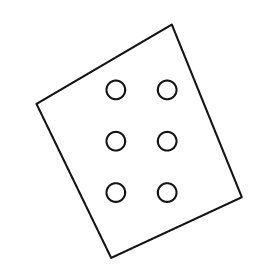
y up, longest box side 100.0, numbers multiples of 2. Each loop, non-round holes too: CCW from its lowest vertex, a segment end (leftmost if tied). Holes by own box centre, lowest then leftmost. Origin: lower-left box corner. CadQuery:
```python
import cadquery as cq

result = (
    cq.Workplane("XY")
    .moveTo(32.0, 0.0)
    .lineTo(88.0, 26.0)
    .lineTo(58.0, 100.0)
    .lineTo(0.0, 66.0)
    .close()
    .moveTo(34.0, 28.0)
    .circle(4.0)
    .moveTo(56.0, 28.0)
    .circle(4.0)
    .moveTo(34.0, 50.0)
    .circle(4.0)
    .moveTo(56.0, 50.0)
    .circle(4.0)
    .moveTo(34.0, 72.0)
    .circle(4.0)
    .moveTo(56.0, 72.0)
    .circle(4.0)
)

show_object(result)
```